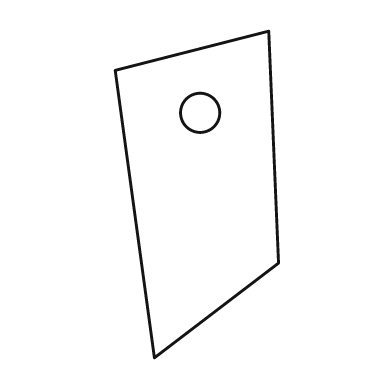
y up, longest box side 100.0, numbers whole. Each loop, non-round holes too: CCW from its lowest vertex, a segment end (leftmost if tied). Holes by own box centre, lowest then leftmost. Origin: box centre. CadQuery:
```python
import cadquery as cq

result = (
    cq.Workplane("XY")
    .moveTo(-13.0, -50.0)
    .lineTo(25.0, -21.0)
    .lineTo(22.0, 50.0)
    .lineTo(-25.0, 38.0)
    .close()
    .moveTo(1.0, 25.0)
    .circle(6.0)
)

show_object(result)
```